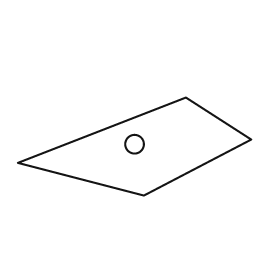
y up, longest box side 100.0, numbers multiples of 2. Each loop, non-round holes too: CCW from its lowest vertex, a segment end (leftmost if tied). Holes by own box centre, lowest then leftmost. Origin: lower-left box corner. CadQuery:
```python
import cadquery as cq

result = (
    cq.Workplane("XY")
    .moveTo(54.0, 0.0)
    .lineTo(100.0, 24.0)
    .lineTo(72.0, 42.0)
    .lineTo(0.0, 14.0)
    .close()
    .moveTo(50.0, 22.0)
    .circle(4.0)
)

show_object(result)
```